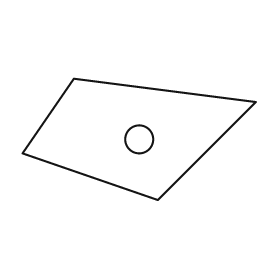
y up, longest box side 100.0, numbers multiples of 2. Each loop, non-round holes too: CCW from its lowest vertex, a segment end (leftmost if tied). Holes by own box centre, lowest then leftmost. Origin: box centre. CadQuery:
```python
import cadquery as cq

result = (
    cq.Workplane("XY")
    .moveTo(8.0, -26.0)
    .lineTo(50.0, 16.0)
    .lineTo(-28.0, 26.0)
    .lineTo(-50.0, -6.0)
    .close()
    .moveTo(0.0, 0.0)
    .circle(6.0)
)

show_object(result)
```